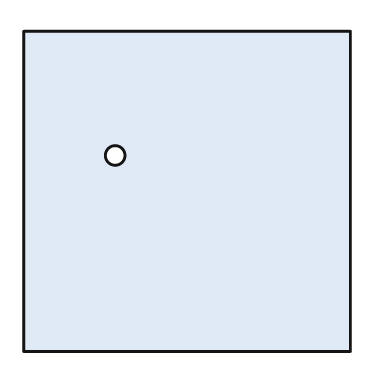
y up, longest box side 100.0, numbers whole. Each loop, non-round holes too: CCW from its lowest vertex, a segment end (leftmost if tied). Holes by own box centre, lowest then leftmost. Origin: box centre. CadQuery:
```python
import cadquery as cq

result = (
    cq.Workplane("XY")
    .moveTo(-50.0, -49.0)
    .lineTo(50.0, -49.0)
    .lineTo(50.0, 49.0)
    .lineTo(-50.0, 49.0)
    .close()
    .moveTo(-22.0, 11.0)
    .circle(3.0)
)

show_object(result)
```